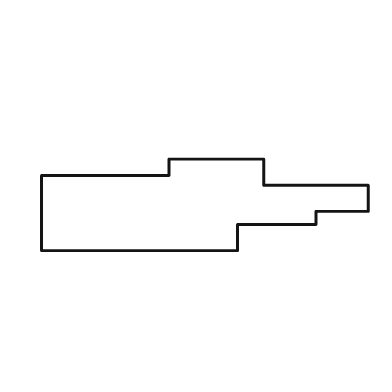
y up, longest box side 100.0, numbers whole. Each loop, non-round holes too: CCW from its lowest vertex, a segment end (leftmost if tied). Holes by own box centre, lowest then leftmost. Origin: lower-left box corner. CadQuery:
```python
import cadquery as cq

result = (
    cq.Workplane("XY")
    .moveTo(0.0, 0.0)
    .lineTo(60.0, 0.0)
    .lineTo(60.0, 8.0)
    .lineTo(84.0, 8.0)
    .lineTo(84.0, 12.0)
    .lineTo(100.0, 12.0)
    .lineTo(100.0, 20.0)
    .lineTo(68.0, 20.0)
    .lineTo(68.0, 28.0)
    .lineTo(39.0, 28.0)
    .lineTo(39.0, 23.0)
    .lineTo(0.0, 23.0)
    .close()
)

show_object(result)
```